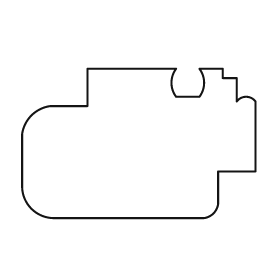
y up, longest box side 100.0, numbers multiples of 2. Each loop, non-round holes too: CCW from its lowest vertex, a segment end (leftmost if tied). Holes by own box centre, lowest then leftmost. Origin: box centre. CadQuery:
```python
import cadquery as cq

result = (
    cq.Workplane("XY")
    .moveTo(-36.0, -32.0)
    .lineTo(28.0, -32.0)
    .threePointArc((32.0, -30.0), (34.0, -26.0))
    .lineTo(34.0, -12.0)
    .lineTo(50.0, -12.0)
    .lineTo(50.0, 18.0)
    .threePointArc((46.0, 20.0), (42.0, 18.0))
    .lineTo(42.0, 28.0)
    .lineTo(36.0, 28.0)
    .lineTo(36.0, 32.0)
    .lineTo(26.0, 32.0)
    .threePointArc((28.0, 26.0), (26.0, 20.0))
    .lineTo(16.0, 20.0)
    .threePointArc((14.0, 26.0), (16.0, 32.0))
    .lineTo(-22.0, 32.0)
    .lineTo(-22.0, 16.0)
    .lineTo(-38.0, 16.0)
    .threePointArc((-46.0, 12.0), (-50.0, 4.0))
    .lineTo(-50.0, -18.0)
    .threePointArc((-46.0, -28.0), (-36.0, -32.0))
    .close()
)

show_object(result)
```